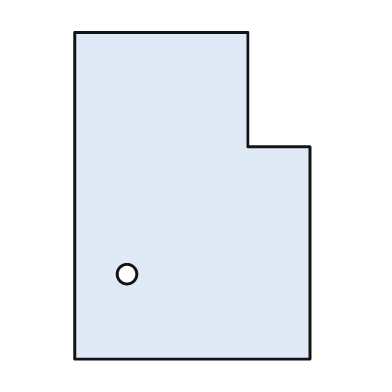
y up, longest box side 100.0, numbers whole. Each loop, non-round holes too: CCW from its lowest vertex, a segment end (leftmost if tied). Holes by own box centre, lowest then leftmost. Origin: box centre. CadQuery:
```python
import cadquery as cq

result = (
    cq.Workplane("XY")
    .moveTo(-36.0, -50.0)
    .lineTo(36.0, -50.0)
    .lineTo(36.0, 15.0)
    .lineTo(17.0, 15.0)
    .lineTo(17.0, 50.0)
    .lineTo(-36.0, 50.0)
    .close()
    .moveTo(-20.0, -24.0)
    .circle(3.0)
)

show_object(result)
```